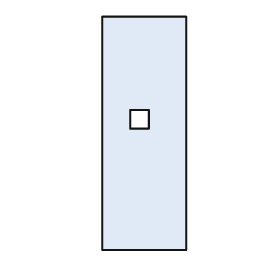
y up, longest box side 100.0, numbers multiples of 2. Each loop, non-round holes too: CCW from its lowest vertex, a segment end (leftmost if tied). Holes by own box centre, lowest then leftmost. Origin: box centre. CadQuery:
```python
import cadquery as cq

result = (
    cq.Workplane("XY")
    .moveTo(-18.0, -50.0)
    .lineTo(18.0, -50.0)
    .lineTo(18.0, 50.0)
    .lineTo(-18.0, 50.0)
    .close()
    .moveTo(-6.0, 2.0)
    .lineTo(2.0, 2.0)
    .lineTo(2.0, 10.0)
    .lineTo(-6.0, 10.0)
    .close()
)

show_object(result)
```